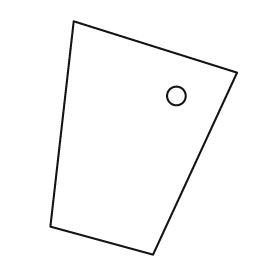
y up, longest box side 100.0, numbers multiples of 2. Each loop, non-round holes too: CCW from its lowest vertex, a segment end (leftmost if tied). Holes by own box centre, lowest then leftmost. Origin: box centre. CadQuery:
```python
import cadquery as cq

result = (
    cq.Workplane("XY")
    .moveTo(4.0, -50.0)
    .lineTo(40.0, 28.0)
    .lineTo(-30.0, 50.0)
    .lineTo(-40.0, -38.0)
    .close()
    .moveTo(14.0, 18.0)
    .circle(4.0)
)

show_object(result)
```